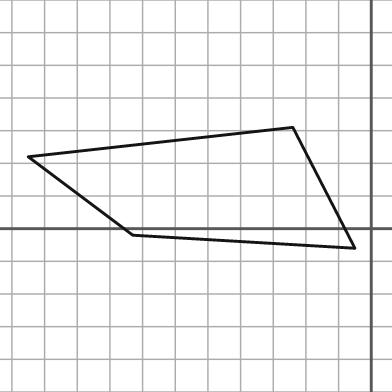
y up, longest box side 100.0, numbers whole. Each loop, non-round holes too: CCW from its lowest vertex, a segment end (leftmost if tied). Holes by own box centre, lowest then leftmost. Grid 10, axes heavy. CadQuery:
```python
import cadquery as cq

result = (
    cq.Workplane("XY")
    .moveTo(-5.0, -6.0)
    .lineTo(-24.0, 31.0)
    .lineTo(-105.0, 22.0)
    .lineTo(-73.0, -2.0)
    .close()
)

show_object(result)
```